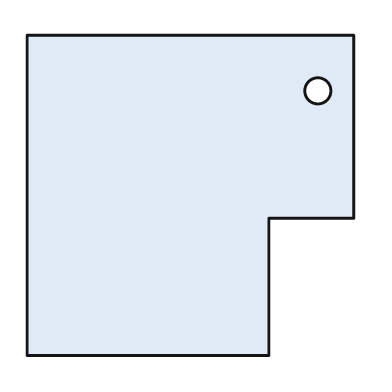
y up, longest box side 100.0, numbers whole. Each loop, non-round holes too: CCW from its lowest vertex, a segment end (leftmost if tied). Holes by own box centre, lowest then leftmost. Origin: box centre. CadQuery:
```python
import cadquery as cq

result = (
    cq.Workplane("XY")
    .moveTo(-50.0, -49.0)
    .lineTo(24.0, -49.0)
    .lineTo(24.0, -7.0)
    .lineTo(50.0, -7.0)
    .lineTo(50.0, 49.0)
    .lineTo(-50.0, 49.0)
    .close()
    .moveTo(39.0, 32.0)
    .circle(4.0)
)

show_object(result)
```